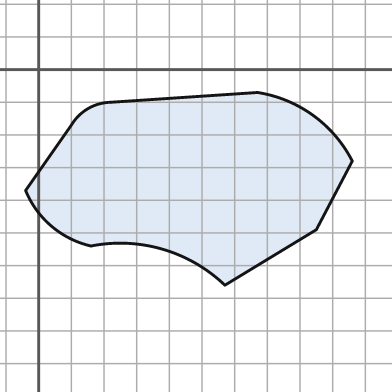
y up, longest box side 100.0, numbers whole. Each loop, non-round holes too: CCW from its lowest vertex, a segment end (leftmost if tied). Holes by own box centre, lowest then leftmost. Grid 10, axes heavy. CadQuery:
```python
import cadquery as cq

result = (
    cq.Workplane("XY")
    .moveTo(57.0, -66.0)
    .lineTo(85.0, -49.0)
    .lineTo(96.0, -28.0)
    .threePointArc((84.0, -14.0), (67.0, -7.0))
    .lineTo(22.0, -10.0)
    .threePointArc((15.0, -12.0), (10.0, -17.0))
    .lineTo(-4.0, -37.0)
    .threePointArc((4.0, -48.0), (16.0, -54.0))
    .threePointArc((38.0, -55.0), (57.0, -66.0))
    .close()
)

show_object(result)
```